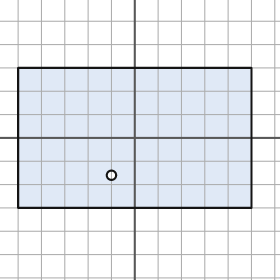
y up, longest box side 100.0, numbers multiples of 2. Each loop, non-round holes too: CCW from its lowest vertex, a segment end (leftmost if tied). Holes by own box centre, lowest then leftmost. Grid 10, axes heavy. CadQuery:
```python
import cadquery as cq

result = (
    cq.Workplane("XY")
    .moveTo(-50.0, -30.0)
    .lineTo(50.0, -30.0)
    .lineTo(50.0, 30.0)
    .lineTo(-50.0, 30.0)
    .close()
    .moveTo(-10.0, -16.0)
    .circle(2.0)
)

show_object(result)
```